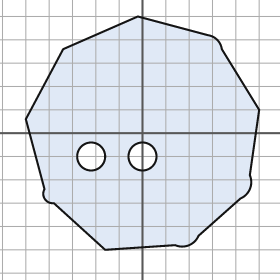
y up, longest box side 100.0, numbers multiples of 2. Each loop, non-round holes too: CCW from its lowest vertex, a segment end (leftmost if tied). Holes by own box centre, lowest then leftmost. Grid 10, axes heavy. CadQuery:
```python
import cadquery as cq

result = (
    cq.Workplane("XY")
    .moveTo(-16.0, -50.0)
    .lineTo(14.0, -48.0)
    .threePointArc((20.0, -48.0), (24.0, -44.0))
    .lineTo(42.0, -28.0)
    .threePointArc((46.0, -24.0), (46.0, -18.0))
    .lineTo(50.0, 10.0)
    .lineTo(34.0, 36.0)
    .threePointArc((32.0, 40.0), (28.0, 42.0))
    .lineTo(-2.0, 50.0)
    .lineTo(-34.0, 36.0)
    .lineTo(-50.0, 6.0)
    .lineTo(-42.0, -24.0)
    .threePointArc((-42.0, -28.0), (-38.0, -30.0))
    .close()
    .moveTo(-22.0, -10.0)
    .circle(6.0)
    .moveTo(0.0, -10.0)
    .circle(6.0)
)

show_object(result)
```